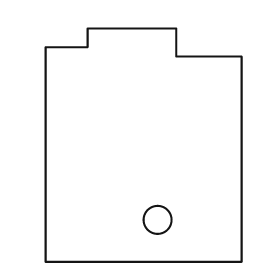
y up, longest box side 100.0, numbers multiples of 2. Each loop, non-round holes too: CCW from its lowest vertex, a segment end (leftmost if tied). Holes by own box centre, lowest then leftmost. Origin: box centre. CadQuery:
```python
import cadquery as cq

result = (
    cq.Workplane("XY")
    .moveTo(-42.0, -50.0)
    .lineTo(42.0, -50.0)
    .lineTo(42.0, 38.0)
    .lineTo(14.0, 38.0)
    .lineTo(14.0, 50.0)
    .lineTo(-24.0, 50.0)
    .lineTo(-24.0, 42.0)
    .lineTo(-42.0, 42.0)
    .close()
    .moveTo(6.0, -32.0)
    .circle(6.0)
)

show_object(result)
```